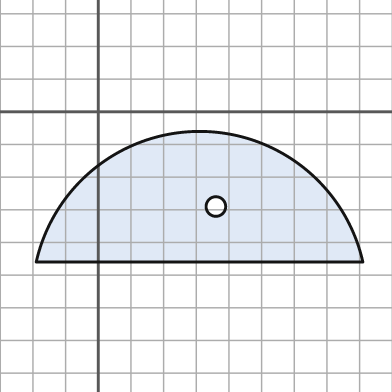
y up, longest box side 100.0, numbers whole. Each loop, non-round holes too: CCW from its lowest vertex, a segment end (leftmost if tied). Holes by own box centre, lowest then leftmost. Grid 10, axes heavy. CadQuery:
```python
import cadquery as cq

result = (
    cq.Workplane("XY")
    .moveTo(-19.0, -46.0)
    .lineTo(81.0, -46.0)
    .threePointArc((31.0, -6.0), (-19.0, -46.0))
    .close()
    .moveTo(36.0, -29.0)
    .circle(3.0)
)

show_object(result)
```